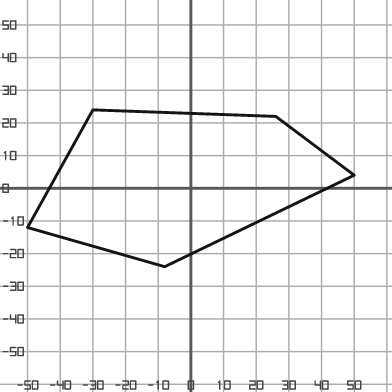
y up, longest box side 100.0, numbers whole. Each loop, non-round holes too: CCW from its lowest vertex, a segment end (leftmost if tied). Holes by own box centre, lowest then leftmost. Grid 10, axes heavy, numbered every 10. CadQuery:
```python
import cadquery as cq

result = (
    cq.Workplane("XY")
    .moveTo(-8.0, -24.0)
    .lineTo(50.0, 4.0)
    .lineTo(26.0, 22.0)
    .lineTo(-30.0, 24.0)
    .lineTo(-50.0, -12.0)
    .close()
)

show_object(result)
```